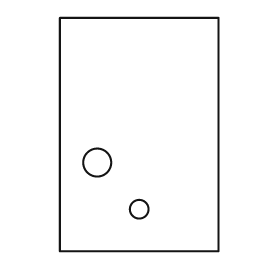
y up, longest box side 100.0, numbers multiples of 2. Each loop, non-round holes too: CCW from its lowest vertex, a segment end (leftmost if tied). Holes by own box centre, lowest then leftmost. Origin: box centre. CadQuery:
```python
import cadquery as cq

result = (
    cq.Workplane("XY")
    .moveTo(-34.0, -50.0)
    .lineTo(34.0, -50.0)
    .lineTo(34.0, 50.0)
    .lineTo(-34.0, 50.0)
    .close()
    .moveTo(0.0, -32.0)
    .circle(4.0)
    .moveTo(-18.0, -12.0)
    .circle(6.0)
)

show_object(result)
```